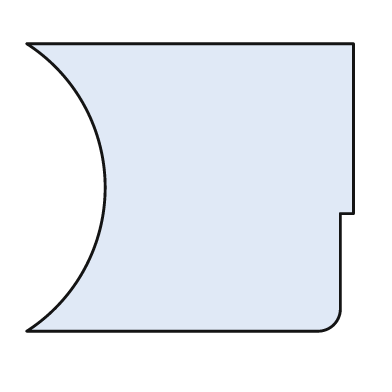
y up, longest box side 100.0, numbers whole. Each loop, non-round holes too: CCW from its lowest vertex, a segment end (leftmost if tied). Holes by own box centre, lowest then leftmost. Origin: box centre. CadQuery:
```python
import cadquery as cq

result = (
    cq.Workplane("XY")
    .moveTo(-50.0, -44.0)
    .lineTo(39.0, -44.0)
    .threePointArc((44.0, -42.0), (46.0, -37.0))
    .lineTo(46.0, -8.0)
    .lineTo(50.0, -8.0)
    .lineTo(50.0, 44.0)
    .lineTo(-50.0, 44.0)
    .threePointArc((-26.0, 0.0), (-50.0, -44.0))
    .close()
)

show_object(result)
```